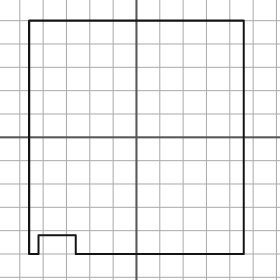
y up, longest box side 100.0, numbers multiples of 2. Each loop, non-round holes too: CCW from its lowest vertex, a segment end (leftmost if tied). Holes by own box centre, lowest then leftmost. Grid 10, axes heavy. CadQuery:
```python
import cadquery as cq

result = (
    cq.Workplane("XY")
    .moveTo(-46.0, -50.0)
    .lineTo(-42.0, -50.0)
    .lineTo(-42.0, -42.0)
    .lineTo(-26.0, -42.0)
    .lineTo(-26.0, -50.0)
    .lineTo(46.0, -50.0)
    .lineTo(46.0, 50.0)
    .lineTo(-46.0, 50.0)
    .close()
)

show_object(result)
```